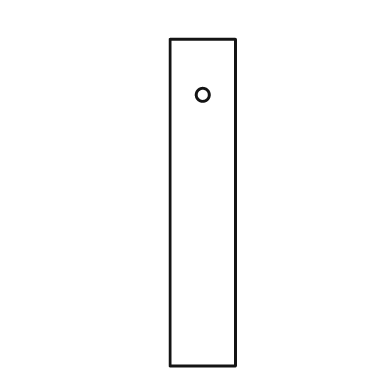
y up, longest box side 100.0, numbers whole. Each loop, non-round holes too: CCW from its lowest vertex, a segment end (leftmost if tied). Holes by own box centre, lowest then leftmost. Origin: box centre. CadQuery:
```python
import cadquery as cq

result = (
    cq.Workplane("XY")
    .moveTo(-10.0, -50.0)
    .lineTo(10.0, -50.0)
    .lineTo(10.0, 50.0)
    .lineTo(-10.0, 50.0)
    .close()
    .moveTo(0.0, 33.0)
    .circle(2.0)
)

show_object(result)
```